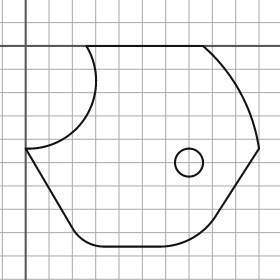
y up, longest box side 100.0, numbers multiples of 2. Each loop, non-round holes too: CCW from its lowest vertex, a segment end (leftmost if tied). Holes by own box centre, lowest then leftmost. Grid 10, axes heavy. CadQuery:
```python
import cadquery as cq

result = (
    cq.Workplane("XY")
    .moveTo(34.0, -86.0)
    .lineTo(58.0, -86.0)
    .threePointArc((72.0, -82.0), (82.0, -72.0))
    .lineTo(100.0, -44.0)
    .threePointArc((92.0, -20.0), (76.0, 0.0))
    .lineTo(26.0, 0.0)
    .threePointArc((26.0, -30.0), (0.0, -44.0))
    .lineTo(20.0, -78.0)
    .threePointArc((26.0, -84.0), (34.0, -86.0))
    .close()
    .moveTo(70.0, -50.0)
    .circle(6.0)
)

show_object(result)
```